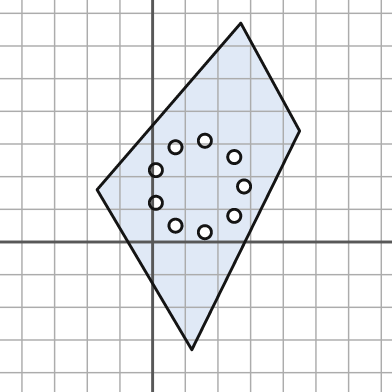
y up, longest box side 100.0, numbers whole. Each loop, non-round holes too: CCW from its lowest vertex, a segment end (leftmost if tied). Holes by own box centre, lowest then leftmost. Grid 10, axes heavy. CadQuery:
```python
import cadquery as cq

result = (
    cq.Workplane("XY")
    .moveTo(12.0, -33.0)
    .lineTo(45.0, 34.0)
    .lineTo(27.0, 67.0)
    .lineTo(-17.0, 16.0)
    .close()
    .moveTo(16.0, 3.0)
    .circle(2.0)
    .moveTo(7.0, 5.0)
    .circle(2.0)
    .moveTo(25.0, 8.0)
    .circle(2.0)
    .moveTo(1.0, 12.0)
    .circle(2.0)
    .moveTo(28.0, 17.0)
    .circle(2.0)
    .moveTo(1.0, 22.0)
    .circle(2.0)
    .moveTo(25.0, 26.0)
    .circle(2.0)
    .moveTo(7.0, 29.0)
    .circle(2.0)
    .moveTo(16.0, 31.0)
    .circle(2.0)
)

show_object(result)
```